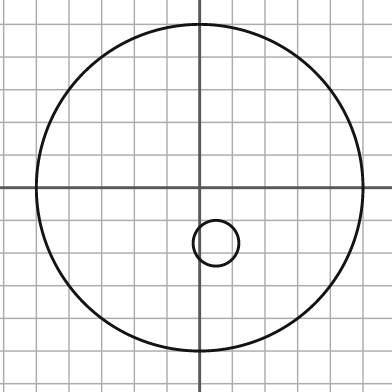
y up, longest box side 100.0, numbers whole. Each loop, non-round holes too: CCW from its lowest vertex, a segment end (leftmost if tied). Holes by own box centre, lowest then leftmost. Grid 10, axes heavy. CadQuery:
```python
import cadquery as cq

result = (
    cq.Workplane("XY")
    .moveTo(0.0, 0.0)
    .circle(50.0)
    .moveTo(5.0, -17.0)
    .circle(7.0)
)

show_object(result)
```